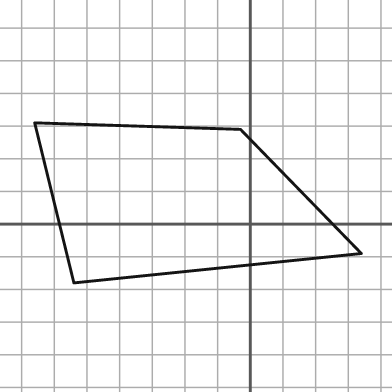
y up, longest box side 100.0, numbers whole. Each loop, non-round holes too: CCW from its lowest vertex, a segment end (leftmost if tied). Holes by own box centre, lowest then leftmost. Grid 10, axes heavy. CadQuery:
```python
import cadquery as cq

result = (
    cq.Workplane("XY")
    .moveTo(-54.0, -18.0)
    .lineTo(34.0, -9.0)
    .lineTo(-3.0, 29.0)
    .lineTo(-66.0, 31.0)
    .close()
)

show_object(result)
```